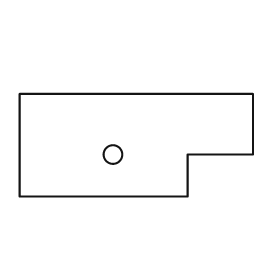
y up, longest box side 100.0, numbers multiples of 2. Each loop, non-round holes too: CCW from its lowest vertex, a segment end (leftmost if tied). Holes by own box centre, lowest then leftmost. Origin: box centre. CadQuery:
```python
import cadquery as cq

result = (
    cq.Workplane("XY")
    .moveTo(-50.0, -22.0)
    .lineTo(22.0, -22.0)
    .lineTo(22.0, -4.0)
    .lineTo(50.0, -4.0)
    .lineTo(50.0, 22.0)
    .lineTo(-50.0, 22.0)
    .close()
    .moveTo(-10.0, -4.0)
    .circle(4.0)
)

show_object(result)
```